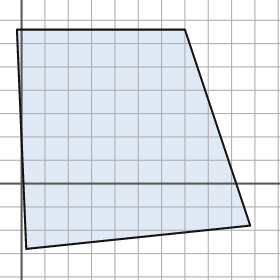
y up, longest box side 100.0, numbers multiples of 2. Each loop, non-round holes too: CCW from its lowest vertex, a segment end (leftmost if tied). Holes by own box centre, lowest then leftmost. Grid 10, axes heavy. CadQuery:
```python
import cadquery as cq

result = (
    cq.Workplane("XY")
    .moveTo(2.0, -28.0)
    .lineTo(98.0, -18.0)
    .lineTo(70.0, 66.0)
    .lineTo(-2.0, 66.0)
    .close()
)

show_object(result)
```